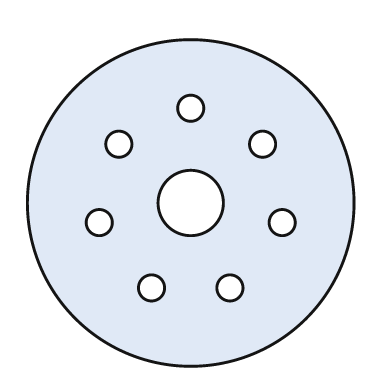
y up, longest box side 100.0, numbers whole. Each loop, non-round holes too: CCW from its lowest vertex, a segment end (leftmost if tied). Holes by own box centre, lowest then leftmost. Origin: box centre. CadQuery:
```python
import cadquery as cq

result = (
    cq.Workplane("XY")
    .moveTo(0.0, 0.0)
    .circle(50.0)
    .moveTo(-12.0, -26.0)
    .circle(4.0)
    .moveTo(12.0, -26.0)
    .circle(4.0)
    .moveTo(-28.0, -6.0)
    .circle(4.0)
    .moveTo(28.0, -6.0)
    .circle(4.0)
    .moveTo(0.0, 0.0)
    .circle(10.0)
    .moveTo(-22.0, 18.0)
    .circle(4.0)
    .moveTo(22.0, 18.0)
    .circle(4.0)
    .moveTo(0.0, 29.0)
    .circle(4.0)
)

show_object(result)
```